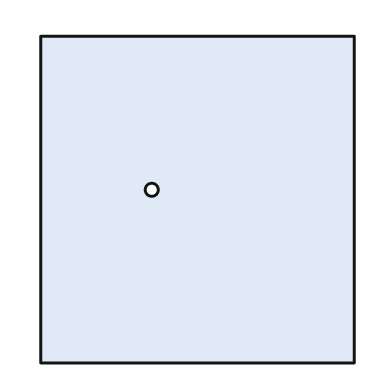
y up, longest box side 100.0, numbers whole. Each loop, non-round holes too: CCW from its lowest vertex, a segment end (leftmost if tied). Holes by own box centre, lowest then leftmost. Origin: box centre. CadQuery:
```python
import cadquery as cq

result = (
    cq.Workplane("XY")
    .moveTo(-48.0, -50.0)
    .lineTo(48.0, -50.0)
    .lineTo(48.0, 50.0)
    .lineTo(-48.0, 50.0)
    .close()
    .moveTo(-14.0, 3.0)
    .circle(2.0)
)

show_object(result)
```